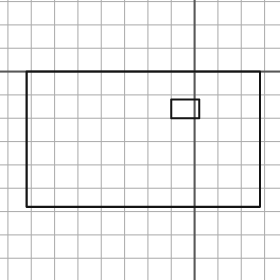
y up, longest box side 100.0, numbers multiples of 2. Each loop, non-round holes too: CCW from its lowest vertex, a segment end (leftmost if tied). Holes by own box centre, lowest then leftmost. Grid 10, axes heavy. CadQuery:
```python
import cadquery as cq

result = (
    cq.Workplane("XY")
    .moveTo(-72.0, -58.0)
    .lineTo(28.0, -58.0)
    .lineTo(28.0, 0.0)
    .lineTo(-72.0, 0.0)
    .close()
    .moveTo(-10.0, -20.0)
    .lineTo(2.0, -20.0)
    .lineTo(2.0, -12.0)
    .lineTo(-10.0, -12.0)
    .close()
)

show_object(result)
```